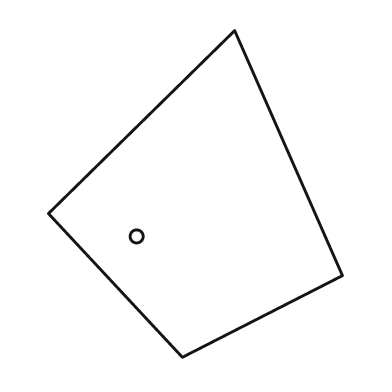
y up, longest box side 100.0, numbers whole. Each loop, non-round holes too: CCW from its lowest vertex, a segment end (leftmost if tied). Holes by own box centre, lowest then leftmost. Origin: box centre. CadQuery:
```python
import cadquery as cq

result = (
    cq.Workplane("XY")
    .moveTo(-4.0, -50.0)
    .lineTo(45.0, -25.0)
    .lineTo(12.0, 50.0)
    .lineTo(-45.0, -6.0)
    .close()
    .moveTo(-18.0, -13.0)
    .circle(2.0)
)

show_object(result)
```